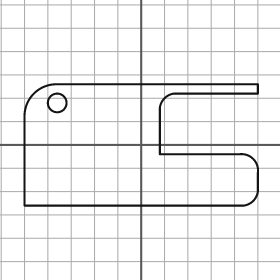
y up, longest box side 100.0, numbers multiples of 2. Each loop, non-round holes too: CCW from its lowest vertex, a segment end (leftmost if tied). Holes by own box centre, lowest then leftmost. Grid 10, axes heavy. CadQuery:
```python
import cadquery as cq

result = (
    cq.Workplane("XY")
    .moveTo(-50.0, -26.0)
    .lineTo(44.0, -26.0)
    .threePointArc((48.0, -24.0), (50.0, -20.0))
    .lineTo(50.0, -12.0)
    .threePointArc((48.0, -6.0), (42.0, -4.0))
    .lineTo(8.0, -4.0)
    .lineTo(8.0, 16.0)
    .threePointArc((10.0, 20.0), (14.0, 22.0))
    .lineTo(50.0, 22.0)
    .lineTo(50.0, 26.0)
    .lineTo(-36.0, 26.0)
    .threePointArc((-46.0, 22.0), (-50.0, 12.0))
    .close()
    .moveTo(-36.0, 18.0)
    .circle(4.0)
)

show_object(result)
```